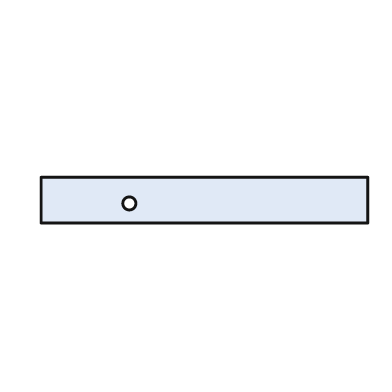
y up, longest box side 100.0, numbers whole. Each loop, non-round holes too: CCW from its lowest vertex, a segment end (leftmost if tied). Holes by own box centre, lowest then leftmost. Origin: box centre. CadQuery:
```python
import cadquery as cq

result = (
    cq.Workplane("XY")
    .moveTo(-50.0, -7.0)
    .lineTo(50.0, -7.0)
    .lineTo(50.0, 7.0)
    .lineTo(-50.0, 7.0)
    .close()
    .moveTo(-23.0, -1.0)
    .circle(2.0)
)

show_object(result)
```